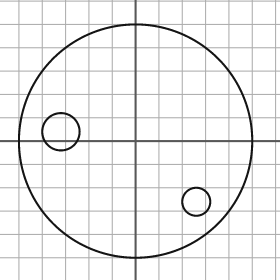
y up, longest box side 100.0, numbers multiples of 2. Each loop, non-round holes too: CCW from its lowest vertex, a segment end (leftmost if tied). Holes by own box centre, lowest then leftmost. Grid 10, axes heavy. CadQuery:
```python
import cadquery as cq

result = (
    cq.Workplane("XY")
    .moveTo(0.0, 0.0)
    .circle(50.0)
    .moveTo(26.0, -26.0)
    .circle(6.0)
    .moveTo(-32.0, 4.0)
    .circle(8.0)
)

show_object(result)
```